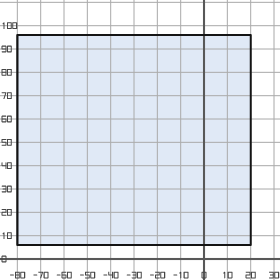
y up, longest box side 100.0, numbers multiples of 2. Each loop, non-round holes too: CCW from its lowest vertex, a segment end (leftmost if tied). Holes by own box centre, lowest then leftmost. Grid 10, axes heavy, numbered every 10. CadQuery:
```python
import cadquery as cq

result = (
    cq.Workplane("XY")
    .moveTo(-80.0, 6.0)
    .lineTo(20.0, 6.0)
    .lineTo(20.0, 96.0)
    .lineTo(-80.0, 96.0)
    .close()
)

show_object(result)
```